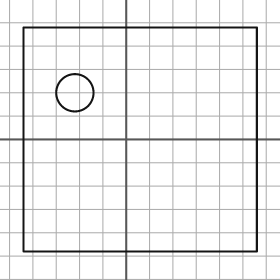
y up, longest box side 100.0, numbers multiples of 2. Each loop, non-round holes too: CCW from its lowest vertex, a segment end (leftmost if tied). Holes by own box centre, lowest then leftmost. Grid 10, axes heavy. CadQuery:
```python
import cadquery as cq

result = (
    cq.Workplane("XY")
    .moveTo(-44.0, -48.0)
    .lineTo(56.0, -48.0)
    .lineTo(56.0, 48.0)
    .lineTo(-44.0, 48.0)
    .close()
    .moveTo(-22.0, 20.0)
    .circle(8.0)
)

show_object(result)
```